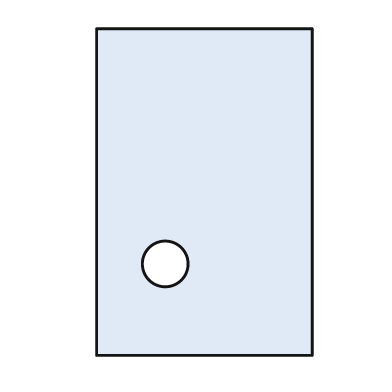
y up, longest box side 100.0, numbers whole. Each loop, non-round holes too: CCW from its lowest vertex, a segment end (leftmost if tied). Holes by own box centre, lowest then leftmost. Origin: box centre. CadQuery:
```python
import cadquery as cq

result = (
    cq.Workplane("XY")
    .moveTo(-33.0, -50.0)
    .lineTo(33.0, -50.0)
    .lineTo(33.0, 50.0)
    .lineTo(-33.0, 50.0)
    .close()
    .moveTo(-12.0, -22.0)
    .circle(7.0)
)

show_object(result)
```